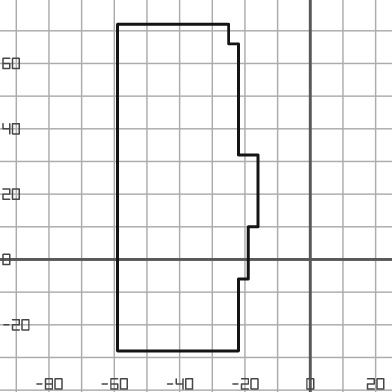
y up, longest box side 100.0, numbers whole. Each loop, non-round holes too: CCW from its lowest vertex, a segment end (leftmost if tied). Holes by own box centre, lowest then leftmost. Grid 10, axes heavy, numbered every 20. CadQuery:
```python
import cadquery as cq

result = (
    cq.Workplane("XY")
    .moveTo(-59.0, -28.0)
    .lineTo(-22.0, -28.0)
    .lineTo(-22.0, -6.0)
    .lineTo(-19.0, -6.0)
    .lineTo(-19.0, 10.0)
    .lineTo(-16.0, 10.0)
    .lineTo(-16.0, 32.0)
    .lineTo(-22.0, 32.0)
    .lineTo(-22.0, 66.0)
    .lineTo(-25.0, 66.0)
    .lineTo(-25.0, 72.0)
    .lineTo(-59.0, 72.0)
    .close()
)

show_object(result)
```